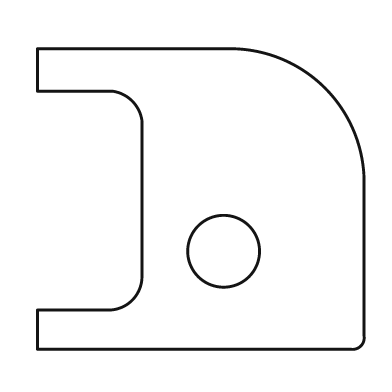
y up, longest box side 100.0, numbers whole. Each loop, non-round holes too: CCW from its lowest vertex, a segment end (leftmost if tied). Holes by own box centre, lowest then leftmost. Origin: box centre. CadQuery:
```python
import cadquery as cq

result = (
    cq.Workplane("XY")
    .moveTo(-50.0, -46.0)
    .lineTo(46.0, -46.0)
    .threePointArc((49.0, -45.0), (50.0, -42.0))
    .lineTo(50.0, 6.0)
    .threePointArc((38.0, 34.0), (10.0, 46.0))
    .lineTo(-50.0, 46.0)
    .lineTo(-50.0, 33.0)
    .lineTo(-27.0, 33.0)
    .threePointArc((-21.0, 30.0), (-18.0, 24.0))
    .lineTo(-18.0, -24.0)
    .threePointArc((-21.0, -31.0), (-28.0, -34.0))
    .lineTo(-50.0, -34.0)
    .close()
    .moveTo(7.0, -16.0)
    .circle(11.0)
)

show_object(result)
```